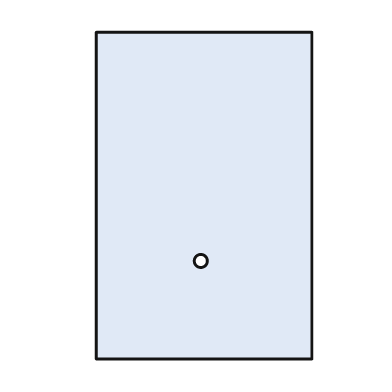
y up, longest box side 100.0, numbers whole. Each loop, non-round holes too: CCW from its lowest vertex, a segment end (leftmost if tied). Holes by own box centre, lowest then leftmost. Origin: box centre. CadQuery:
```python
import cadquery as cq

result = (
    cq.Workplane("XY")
    .moveTo(-33.0, -50.0)
    .lineTo(33.0, -50.0)
    .lineTo(33.0, 50.0)
    .lineTo(-33.0, 50.0)
    .close()
    .moveTo(-1.0, -20.0)
    .circle(2.0)
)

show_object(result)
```